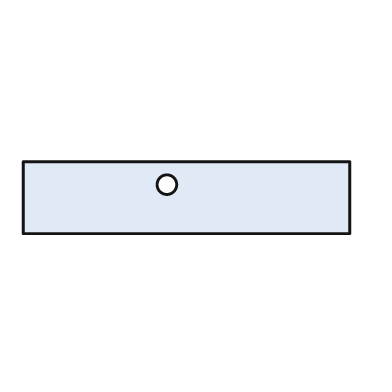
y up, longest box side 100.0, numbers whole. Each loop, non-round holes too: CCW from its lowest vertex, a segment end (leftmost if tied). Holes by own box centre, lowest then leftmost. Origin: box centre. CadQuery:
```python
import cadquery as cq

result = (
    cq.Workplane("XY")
    .moveTo(-50.0, -11.0)
    .lineTo(50.0, -11.0)
    .lineTo(50.0, 11.0)
    .lineTo(-50.0, 11.0)
    .close()
    .moveTo(-6.0, 4.0)
    .circle(3.0)
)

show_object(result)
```